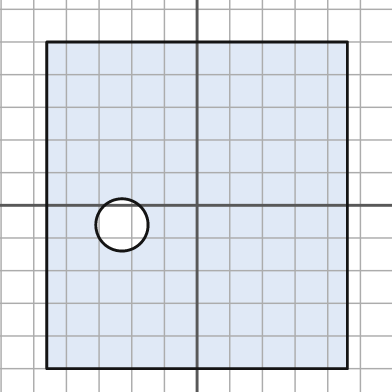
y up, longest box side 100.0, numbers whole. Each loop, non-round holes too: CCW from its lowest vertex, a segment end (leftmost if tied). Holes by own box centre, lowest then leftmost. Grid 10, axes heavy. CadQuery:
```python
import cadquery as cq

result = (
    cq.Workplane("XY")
    .moveTo(-46.0, -50.0)
    .lineTo(46.0, -50.0)
    .lineTo(46.0, 50.0)
    .lineTo(-46.0, 50.0)
    .close()
    .moveTo(-23.0, -6.0)
    .circle(8.0)
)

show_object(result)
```